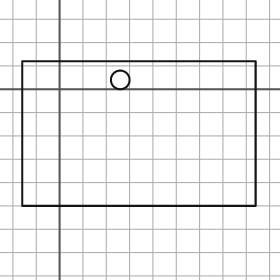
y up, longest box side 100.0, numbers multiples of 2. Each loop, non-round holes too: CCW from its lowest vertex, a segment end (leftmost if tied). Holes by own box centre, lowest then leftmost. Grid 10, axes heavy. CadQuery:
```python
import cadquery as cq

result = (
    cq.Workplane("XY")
    .moveTo(-16.0, -50.0)
    .lineTo(84.0, -50.0)
    .lineTo(84.0, 12.0)
    .lineTo(-16.0, 12.0)
    .close()
    .moveTo(26.0, 4.0)
    .circle(4.0)
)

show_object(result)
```